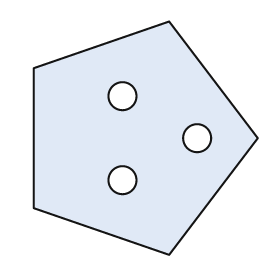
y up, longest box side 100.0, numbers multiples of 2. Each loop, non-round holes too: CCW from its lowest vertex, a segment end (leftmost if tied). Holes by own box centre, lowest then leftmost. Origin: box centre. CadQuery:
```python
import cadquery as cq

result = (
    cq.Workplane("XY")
    .moveTo(10.0, -50.0)
    .lineTo(48.0, 0.0)
    .lineTo(10.0, 50.0)
    .lineTo(-48.0, 30.0)
    .lineTo(-48.0, -30.0)
    .close()
    .moveTo(-10.0, -18.0)
    .circle(6.0)
    .moveTo(22.0, 0.0)
    .circle(6.0)
    .moveTo(-10.0, 18.0)
    .circle(6.0)
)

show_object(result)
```